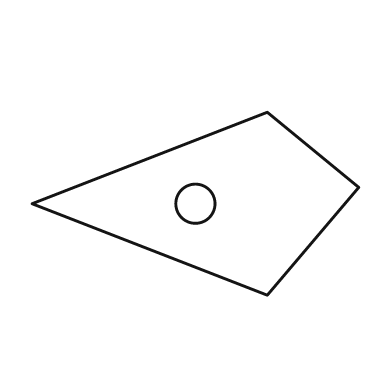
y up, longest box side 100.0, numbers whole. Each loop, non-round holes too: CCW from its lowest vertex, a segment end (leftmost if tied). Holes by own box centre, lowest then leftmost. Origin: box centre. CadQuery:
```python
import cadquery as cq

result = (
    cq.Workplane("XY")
    .moveTo(22.0, -28.0)
    .lineTo(50.0, 5.0)
    .lineTo(22.0, 28.0)
    .lineTo(-50.0, 0.0)
    .close()
    .moveTo(0.0, 0.0)
    .circle(6.0)
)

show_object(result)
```